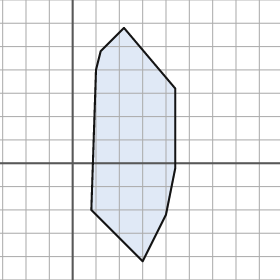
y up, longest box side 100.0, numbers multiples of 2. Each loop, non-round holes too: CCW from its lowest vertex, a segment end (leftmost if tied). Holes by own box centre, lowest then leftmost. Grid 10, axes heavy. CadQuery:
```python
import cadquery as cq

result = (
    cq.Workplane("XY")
    .moveTo(30.0, -42.0)
    .lineTo(40.0, -22.0)
    .lineTo(44.0, -2.0)
    .lineTo(44.0, 32.0)
    .lineTo(22.0, 58.0)
    .lineTo(12.0, 48.0)
    .lineTo(10.0, 40.0)
    .lineTo(8.0, -20.0)
    .close()
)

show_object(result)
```